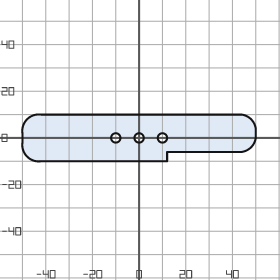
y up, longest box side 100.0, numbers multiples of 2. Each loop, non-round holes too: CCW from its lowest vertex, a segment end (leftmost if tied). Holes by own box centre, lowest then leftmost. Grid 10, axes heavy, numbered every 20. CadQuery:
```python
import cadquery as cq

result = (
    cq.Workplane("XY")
    .moveTo(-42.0, -10.0)
    .lineTo(12.0, -10.0)
    .lineTo(12.0, -6.0)
    .lineTo(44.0, -6.0)
    .threePointArc((48.0, -4.0), (50.0, 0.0))
    .lineTo(50.0, 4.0)
    .threePointArc((48.0, 8.0), (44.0, 10.0))
    .lineTo(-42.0, 10.0)
    .threePointArc((-48.0, 8.0), (-50.0, 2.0))
    .lineTo(-50.0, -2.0)
    .threePointArc((-48.0, -8.0), (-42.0, -10.0))
    .close()
    .moveTo(-10.0, 0.0)
    .circle(2.0)
    .moveTo(0.0, 0.0)
    .circle(2.0)
    .moveTo(10.0, 0.0)
    .circle(2.0)
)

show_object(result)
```